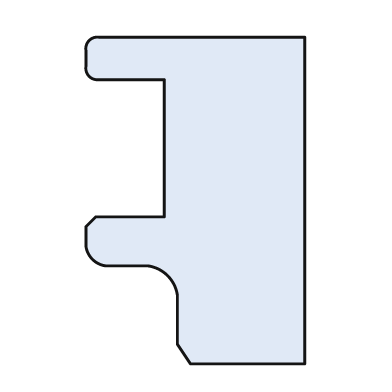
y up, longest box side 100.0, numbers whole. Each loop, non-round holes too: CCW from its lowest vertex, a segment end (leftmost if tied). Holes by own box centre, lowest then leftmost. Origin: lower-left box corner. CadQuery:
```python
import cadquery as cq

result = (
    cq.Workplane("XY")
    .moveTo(32.0, 0.0)
    .lineTo(67.0, 0.0)
    .lineTo(67.0, 100.0)
    .lineTo(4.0, 100.0)
    .threePointArc((1.0, 99.0), (0.0, 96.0))
    .lineTo(0.0, 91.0)
    .threePointArc((1.0, 88.0), (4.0, 87.0))
    .lineTo(24.0, 87.0)
    .lineTo(24.0, 45.0)
    .lineTo(3.0, 45.0)
    .lineTo(0.0, 42.0)
    .lineTo(0.0, 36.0)
    .threePointArc((2.0, 32.0), (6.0, 30.0))
    .lineTo(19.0, 30.0)
    .threePointArc((25.0, 27.0), (28.0, 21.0))
    .lineTo(28.0, 6.0)
    .close()
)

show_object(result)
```